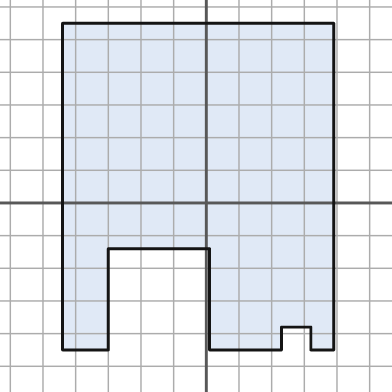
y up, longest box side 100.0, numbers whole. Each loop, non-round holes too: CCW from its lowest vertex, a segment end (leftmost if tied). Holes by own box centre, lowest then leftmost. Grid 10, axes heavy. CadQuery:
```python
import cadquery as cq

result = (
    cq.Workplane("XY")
    .moveTo(-44.0, -45.0)
    .lineTo(-30.0, -45.0)
    .lineTo(-30.0, -14.0)
    .lineTo(1.0, -14.0)
    .lineTo(1.0, -45.0)
    .lineTo(23.0, -45.0)
    .lineTo(23.0, -38.0)
    .lineTo(32.0, -38.0)
    .lineTo(32.0, -45.0)
    .lineTo(39.0, -45.0)
    .lineTo(39.0, 55.0)
    .lineTo(-44.0, 55.0)
    .close()
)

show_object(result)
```